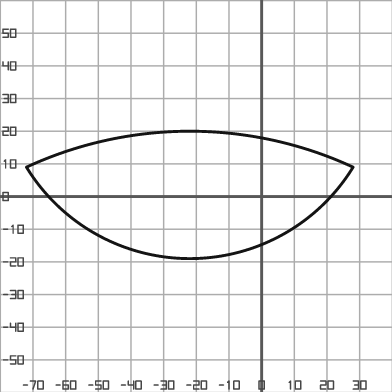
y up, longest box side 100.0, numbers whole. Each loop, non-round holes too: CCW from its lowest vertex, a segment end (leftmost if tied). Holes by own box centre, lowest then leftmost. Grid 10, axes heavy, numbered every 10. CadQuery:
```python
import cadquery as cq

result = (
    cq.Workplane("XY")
    .moveTo(-72.0, 9.0)
    .threePointArc((-22.0, -19.0), (28.0, 9.0))
    .threePointArc((-22.0, 20.0), (-72.0, 9.0))
    .close()
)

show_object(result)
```